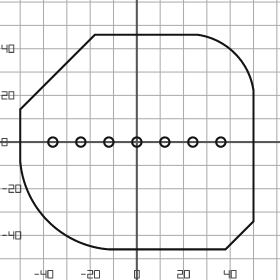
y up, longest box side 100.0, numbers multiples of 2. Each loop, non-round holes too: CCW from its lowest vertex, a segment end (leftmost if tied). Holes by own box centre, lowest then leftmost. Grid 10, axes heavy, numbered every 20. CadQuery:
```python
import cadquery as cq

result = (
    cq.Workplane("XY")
    .moveTo(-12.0, -46.0)
    .lineTo(38.0, -46.0)
    .lineTo(50.0, -34.0)
    .lineTo(50.0, 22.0)
    .threePointArc((42.0, 38.0), (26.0, 46.0))
    .lineTo(-18.0, 46.0)
    .lineTo(-50.0, 14.0)
    .lineTo(-50.0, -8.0)
    .threePointArc((-38.0, -34.0), (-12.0, -46.0))
    .close()
    .moveTo(-36.0, 0.0)
    .circle(2.0)
    .moveTo(-24.0, 0.0)
    .circle(2.0)
    .moveTo(-12.0, 0.0)
    .circle(2.0)
    .moveTo(0.0, 0.0)
    .circle(2.0)
    .moveTo(12.0, 0.0)
    .circle(2.0)
    .moveTo(24.0, 0.0)
    .circle(2.0)
    .moveTo(36.0, 0.0)
    .circle(2.0)
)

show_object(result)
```